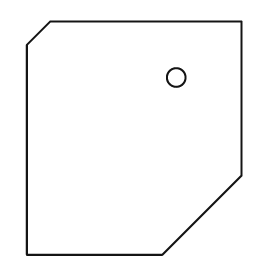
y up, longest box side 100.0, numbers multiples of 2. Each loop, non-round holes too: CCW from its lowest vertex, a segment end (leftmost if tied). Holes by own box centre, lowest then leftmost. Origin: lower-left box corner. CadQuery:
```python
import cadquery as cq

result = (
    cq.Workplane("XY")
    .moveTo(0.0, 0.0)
    .lineTo(58.0, 0.0)
    .lineTo(92.0, 34.0)
    .lineTo(92.0, 100.0)
    .lineTo(10.0, 100.0)
    .lineTo(0.0, 90.0)
    .close()
    .moveTo(64.0, 76.0)
    .circle(4.0)
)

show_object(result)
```